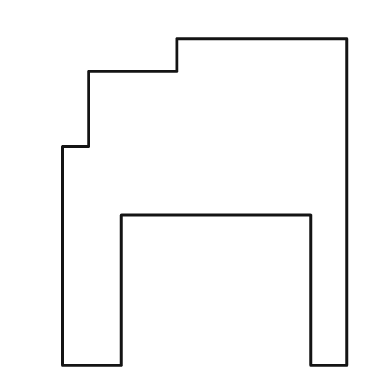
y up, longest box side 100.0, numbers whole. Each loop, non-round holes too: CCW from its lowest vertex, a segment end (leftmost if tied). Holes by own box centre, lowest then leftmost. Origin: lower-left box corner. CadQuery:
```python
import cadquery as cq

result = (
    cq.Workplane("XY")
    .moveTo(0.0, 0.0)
    .lineTo(18.0, 0.0)
    .lineTo(18.0, 46.0)
    .lineTo(76.0, 46.0)
    .lineTo(76.0, 0.0)
    .lineTo(87.0, 0.0)
    .lineTo(87.0, 100.0)
    .lineTo(35.0, 100.0)
    .lineTo(35.0, 90.0)
    .lineTo(8.0, 90.0)
    .lineTo(8.0, 67.0)
    .lineTo(0.0, 67.0)
    .close()
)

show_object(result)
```